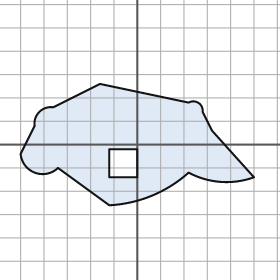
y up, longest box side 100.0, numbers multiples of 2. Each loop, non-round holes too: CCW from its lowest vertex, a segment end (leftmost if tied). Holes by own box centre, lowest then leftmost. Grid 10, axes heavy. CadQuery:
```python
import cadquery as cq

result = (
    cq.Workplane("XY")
    .moveTo(-12.0, -26.0)
    .threePointArc((6.0, -22.0), (22.0, -12.0))
    .threePointArc((36.0, -16.0), (50.0, -14.0))
    .lineTo(32.0, 6.0)
    .lineTo(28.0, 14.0)
    .threePointArc((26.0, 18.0), (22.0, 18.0))
    .lineTo(-16.0, 26.0)
    .lineTo(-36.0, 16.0)
    .threePointArc((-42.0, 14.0), (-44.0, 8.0))
    .lineTo(-50.0, -4.0)
    .threePointArc((-44.0, -12.0), (-34.0, -10.0))
    .close()
    .moveTo(-12.0, -14.0)
    .lineTo(0.0, -14.0)
    .lineTo(0.0, -2.0)
    .lineTo(-12.0, -2.0)
    .close()
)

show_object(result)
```